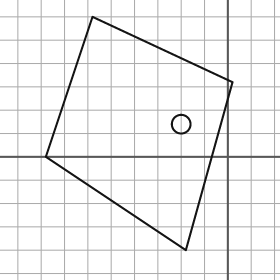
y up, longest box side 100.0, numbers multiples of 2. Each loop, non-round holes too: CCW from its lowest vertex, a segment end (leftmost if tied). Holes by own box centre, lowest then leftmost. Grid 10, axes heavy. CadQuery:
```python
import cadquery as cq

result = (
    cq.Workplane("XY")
    .moveTo(-18.0, -40.0)
    .lineTo(2.0, 32.0)
    .lineTo(-58.0, 60.0)
    .lineTo(-78.0, 0.0)
    .close()
    .moveTo(-20.0, 14.0)
    .circle(4.0)
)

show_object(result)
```